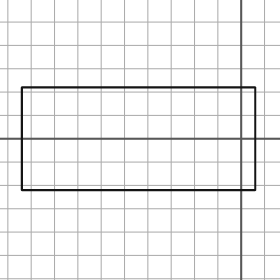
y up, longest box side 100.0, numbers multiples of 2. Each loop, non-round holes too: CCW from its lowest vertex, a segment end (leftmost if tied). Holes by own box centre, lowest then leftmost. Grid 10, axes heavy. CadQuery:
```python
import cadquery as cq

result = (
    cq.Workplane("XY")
    .moveTo(-94.0, -22.0)
    .lineTo(6.0, -22.0)
    .lineTo(6.0, 22.0)
    .lineTo(-94.0, 22.0)
    .close()
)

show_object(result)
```